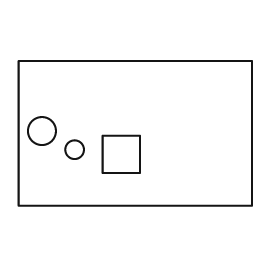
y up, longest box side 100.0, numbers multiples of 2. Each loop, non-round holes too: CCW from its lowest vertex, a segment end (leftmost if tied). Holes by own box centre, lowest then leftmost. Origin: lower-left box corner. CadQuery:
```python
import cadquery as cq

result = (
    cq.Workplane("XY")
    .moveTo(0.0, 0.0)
    .lineTo(100.0, 0.0)
    .lineTo(100.0, 62.0)
    .lineTo(0.0, 62.0)
    .close()
    .moveTo(36.0, 14.0)
    .lineTo(52.0, 14.0)
    .lineTo(52.0, 30.0)
    .lineTo(36.0, 30.0)
    .close()
    .moveTo(24.0, 24.0)
    .circle(4.0)
    .moveTo(10.0, 32.0)
    .circle(6.0)
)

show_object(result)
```